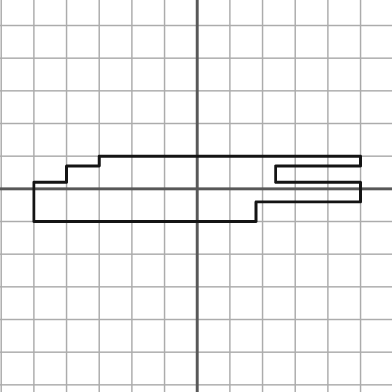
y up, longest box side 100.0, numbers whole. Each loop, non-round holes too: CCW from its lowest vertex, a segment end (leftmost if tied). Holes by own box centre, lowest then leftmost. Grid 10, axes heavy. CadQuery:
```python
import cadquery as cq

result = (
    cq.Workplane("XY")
    .moveTo(-50.0, -10.0)
    .lineTo(18.0, -10.0)
    .lineTo(18.0, -4.0)
    .lineTo(50.0, -4.0)
    .lineTo(50.0, 2.0)
    .lineTo(24.0, 2.0)
    .lineTo(24.0, 7.0)
    .lineTo(50.0, 7.0)
    .lineTo(50.0, 10.0)
    .lineTo(-30.0, 10.0)
    .lineTo(-30.0, 7.0)
    .lineTo(-40.0, 7.0)
    .lineTo(-40.0, 2.0)
    .lineTo(-50.0, 2.0)
    .close()
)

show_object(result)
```